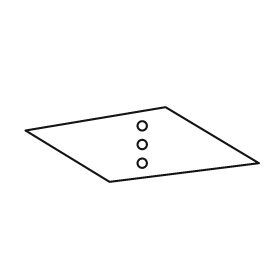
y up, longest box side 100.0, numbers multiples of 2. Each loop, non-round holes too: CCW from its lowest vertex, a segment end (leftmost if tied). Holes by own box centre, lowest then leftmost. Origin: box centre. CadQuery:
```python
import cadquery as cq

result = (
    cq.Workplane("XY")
    .moveTo(-14.0, -16.0)
    .lineTo(50.0, -8.0)
    .lineTo(10.0, 16.0)
    .lineTo(-50.0, 6.0)
    .close()
    .moveTo(0.0, -8.0)
    .circle(2.0)
    .moveTo(0.0, 0.0)
    .circle(2.0)
    .moveTo(0.0, 8.0)
    .circle(2.0)
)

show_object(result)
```